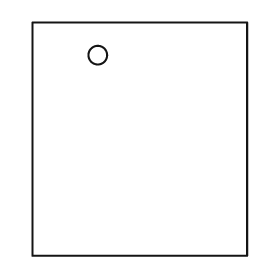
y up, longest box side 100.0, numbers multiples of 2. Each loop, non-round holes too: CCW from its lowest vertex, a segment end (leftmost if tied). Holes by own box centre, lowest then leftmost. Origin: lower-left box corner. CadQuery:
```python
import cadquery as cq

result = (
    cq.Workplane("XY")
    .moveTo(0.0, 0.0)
    .lineTo(92.0, 0.0)
    .lineTo(92.0, 100.0)
    .lineTo(0.0, 100.0)
    .close()
    .moveTo(28.0, 86.0)
    .circle(4.0)
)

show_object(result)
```